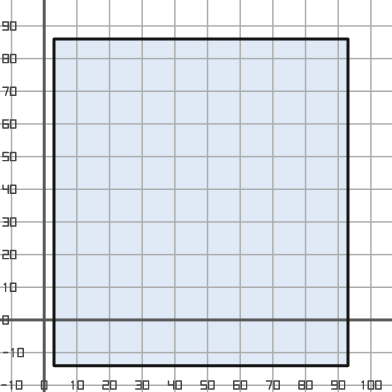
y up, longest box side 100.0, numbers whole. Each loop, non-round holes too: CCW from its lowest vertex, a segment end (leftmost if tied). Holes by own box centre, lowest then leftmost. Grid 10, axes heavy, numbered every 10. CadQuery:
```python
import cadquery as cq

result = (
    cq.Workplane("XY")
    .moveTo(3.0, -14.0)
    .lineTo(93.0, -14.0)
    .lineTo(93.0, 86.0)
    .lineTo(3.0, 86.0)
    .close()
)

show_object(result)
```